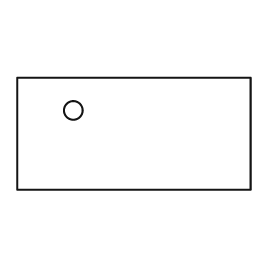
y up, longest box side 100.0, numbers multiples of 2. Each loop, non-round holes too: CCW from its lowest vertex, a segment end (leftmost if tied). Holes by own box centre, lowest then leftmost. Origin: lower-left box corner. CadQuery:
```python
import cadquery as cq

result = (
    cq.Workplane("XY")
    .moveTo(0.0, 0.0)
    .lineTo(100.0, 0.0)
    .lineTo(100.0, 48.0)
    .lineTo(0.0, 48.0)
    .close()
    .moveTo(24.0, 34.0)
    .circle(4.0)
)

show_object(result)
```